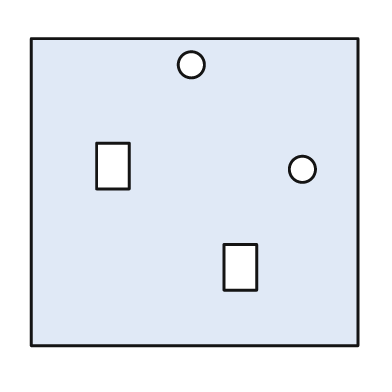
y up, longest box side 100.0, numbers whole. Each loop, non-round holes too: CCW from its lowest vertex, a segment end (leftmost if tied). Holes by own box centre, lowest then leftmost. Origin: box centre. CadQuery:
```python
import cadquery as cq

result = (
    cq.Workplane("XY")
    .moveTo(-50.0, -47.0)
    .lineTo(50.0, -47.0)
    .lineTo(50.0, 47.0)
    .lineTo(-50.0, 47.0)
    .close()
    .moveTo(9.0, -30.0)
    .lineTo(19.0, -30.0)
    .lineTo(19.0, -16.0)
    .lineTo(9.0, -16.0)
    .close()
    .moveTo(33.0, 7.0)
    .circle(4.0)
    .moveTo(-30.0, 1.0)
    .lineTo(-20.0, 1.0)
    .lineTo(-20.0, 15.0)
    .lineTo(-30.0, 15.0)
    .close()
    .moveTo(-1.0, 39.0)
    .circle(4.0)
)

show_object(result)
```